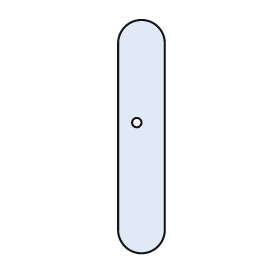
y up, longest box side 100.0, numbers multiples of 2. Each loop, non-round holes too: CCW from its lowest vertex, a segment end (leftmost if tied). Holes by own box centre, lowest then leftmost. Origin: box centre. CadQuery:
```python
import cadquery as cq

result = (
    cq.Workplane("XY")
    .moveTo(-10.0, -40.0)
    .threePointArc((0.0, -50.0), (10.0, -40.0))
    .lineTo(10.0, 40.0)
    .threePointArc((0.0, 50.0), (-10.0, 40.0))
    .close()
    .moveTo(-2.0, 6.0)
    .circle(2.0)
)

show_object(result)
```